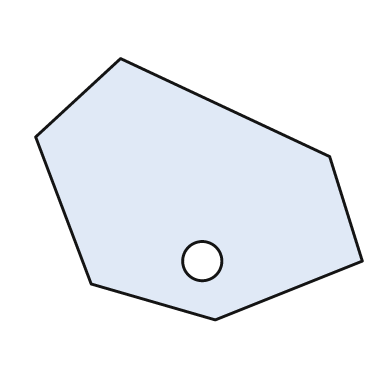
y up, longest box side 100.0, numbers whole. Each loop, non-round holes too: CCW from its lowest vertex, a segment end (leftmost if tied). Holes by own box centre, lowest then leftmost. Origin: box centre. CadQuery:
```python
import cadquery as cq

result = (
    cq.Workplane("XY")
    .moveTo(5.0, -40.0)
    .lineTo(50.0, -22.0)
    .lineTo(40.0, 10.0)
    .lineTo(-24.0, 40.0)
    .lineTo(-50.0, 16.0)
    .lineTo(-33.0, -29.0)
    .close()
    .moveTo(1.0, -22.0)
    .circle(6.0)
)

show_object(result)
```